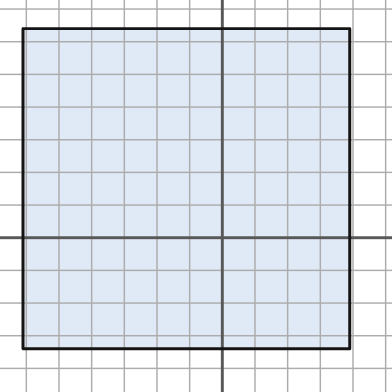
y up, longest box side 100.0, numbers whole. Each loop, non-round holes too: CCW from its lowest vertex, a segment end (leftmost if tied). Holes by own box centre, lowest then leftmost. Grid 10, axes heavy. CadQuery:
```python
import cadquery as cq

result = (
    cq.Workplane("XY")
    .moveTo(-61.0, -34.0)
    .lineTo(39.0, -34.0)
    .lineTo(39.0, 64.0)
    .lineTo(-61.0, 64.0)
    .close()
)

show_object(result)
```